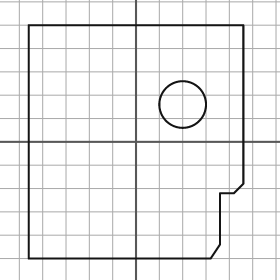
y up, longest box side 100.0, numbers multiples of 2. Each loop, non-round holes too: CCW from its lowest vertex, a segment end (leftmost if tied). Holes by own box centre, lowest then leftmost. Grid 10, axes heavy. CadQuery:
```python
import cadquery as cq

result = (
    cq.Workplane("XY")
    .moveTo(-46.0, -50.0)
    .lineTo(32.0, -50.0)
    .lineTo(36.0, -44.0)
    .lineTo(36.0, -22.0)
    .lineTo(42.0, -22.0)
    .lineTo(46.0, -18.0)
    .lineTo(46.0, 50.0)
    .lineTo(-46.0, 50.0)
    .close()
    .moveTo(20.0, 16.0)
    .circle(10.0)
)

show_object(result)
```